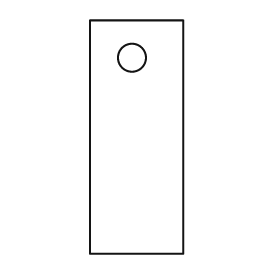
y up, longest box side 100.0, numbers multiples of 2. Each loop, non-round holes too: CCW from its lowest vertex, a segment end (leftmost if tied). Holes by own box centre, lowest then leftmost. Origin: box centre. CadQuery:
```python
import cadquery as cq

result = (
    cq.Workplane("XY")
    .moveTo(-20.0, -50.0)
    .lineTo(20.0, -50.0)
    .lineTo(20.0, 50.0)
    .lineTo(-20.0, 50.0)
    .close()
    .moveTo(-2.0, 34.0)
    .circle(6.0)
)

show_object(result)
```